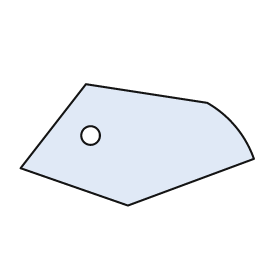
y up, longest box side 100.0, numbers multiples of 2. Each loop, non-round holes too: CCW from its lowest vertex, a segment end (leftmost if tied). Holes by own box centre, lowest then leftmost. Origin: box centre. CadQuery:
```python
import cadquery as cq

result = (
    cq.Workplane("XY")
    .moveTo(-4.0, -26.0)
    .lineTo(50.0, -6.0)
    .threePointArc((42.0, 8.0), (30.0, 18.0))
    .lineTo(-22.0, 26.0)
    .lineTo(-50.0, -10.0)
    .close()
    .moveTo(-20.0, 4.0)
    .circle(4.0)
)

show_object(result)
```